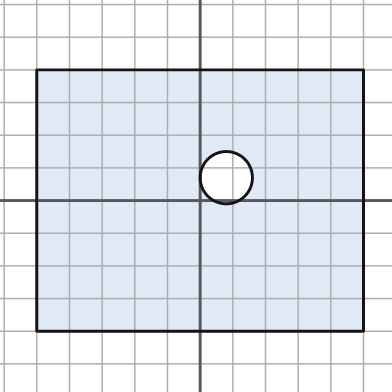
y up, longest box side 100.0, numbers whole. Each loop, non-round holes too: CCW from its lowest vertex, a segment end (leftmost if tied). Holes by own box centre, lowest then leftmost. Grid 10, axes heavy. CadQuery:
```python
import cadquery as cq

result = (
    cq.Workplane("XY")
    .moveTo(-50.0, -40.0)
    .lineTo(50.0, -40.0)
    .lineTo(50.0, 40.0)
    .lineTo(-50.0, 40.0)
    .close()
    .moveTo(8.0, 7.0)
    .circle(8.0)
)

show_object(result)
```